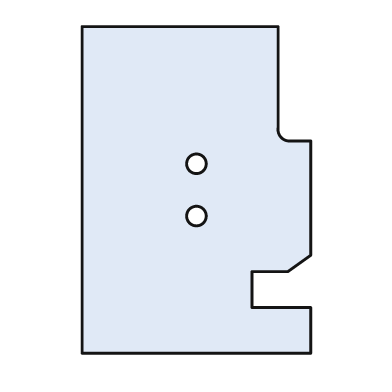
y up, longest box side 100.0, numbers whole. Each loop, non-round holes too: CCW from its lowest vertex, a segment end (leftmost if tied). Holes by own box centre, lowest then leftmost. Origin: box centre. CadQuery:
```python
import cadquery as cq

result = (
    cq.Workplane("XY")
    .moveTo(-35.0, -50.0)
    .lineTo(35.0, -50.0)
    .lineTo(35.0, -36.0)
    .lineTo(17.0, -36.0)
    .lineTo(17.0, -25.0)
    .lineTo(28.0, -25.0)
    .lineTo(35.0, -20.0)
    .lineTo(35.0, 15.0)
    .lineTo(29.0, 15.0)
    .threePointArc((26.0, 16.0), (25.0, 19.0))
    .lineTo(25.0, 50.0)
    .lineTo(-35.0, 50.0)
    .close()
    .moveTo(0.0, -8.0)
    .circle(3.0)
    .moveTo(0.0, 8.0)
    .circle(3.0)
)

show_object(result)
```